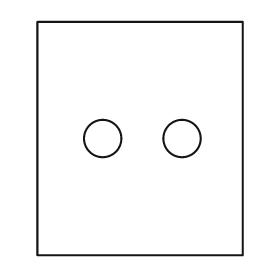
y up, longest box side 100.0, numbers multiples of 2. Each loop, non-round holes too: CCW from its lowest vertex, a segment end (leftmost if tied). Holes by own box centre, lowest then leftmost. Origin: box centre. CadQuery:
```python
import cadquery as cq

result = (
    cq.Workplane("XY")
    .moveTo(-44.0, -50.0)
    .lineTo(44.0, -50.0)
    .lineTo(44.0, 50.0)
    .lineTo(-44.0, 50.0)
    .close()
    .moveTo(-16.0, 0.0)
    .circle(8.0)
    .moveTo(18.0, 0.0)
    .circle(8.0)
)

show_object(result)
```